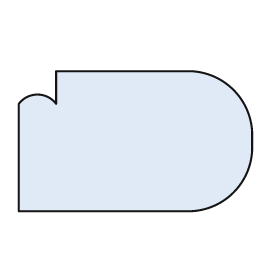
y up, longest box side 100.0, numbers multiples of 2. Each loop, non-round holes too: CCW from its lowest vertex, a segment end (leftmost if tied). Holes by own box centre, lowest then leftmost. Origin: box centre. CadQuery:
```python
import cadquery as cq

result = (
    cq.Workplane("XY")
    .moveTo(-50.0, -30.0)
    .lineTo(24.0, -30.0)
    .threePointArc((42.0, -22.0), (50.0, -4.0))
    .lineTo(50.0, 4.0)
    .threePointArc((42.0, 22.0), (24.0, 30.0))
    .lineTo(-34.0, 30.0)
    .lineTo(-34.0, 16.0)
    .threePointArc((-42.0, 20.0), (-50.0, 16.0))
    .close()
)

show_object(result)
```